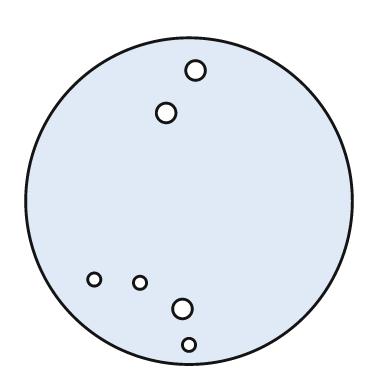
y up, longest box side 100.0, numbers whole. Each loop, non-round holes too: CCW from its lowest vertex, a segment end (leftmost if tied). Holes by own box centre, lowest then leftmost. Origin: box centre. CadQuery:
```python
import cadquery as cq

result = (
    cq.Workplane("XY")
    .moveTo(0.0, 0.0)
    .circle(50.0)
    .moveTo(0.0, -44.0)
    .circle(2.0)
    .moveTo(-2.0, -33.0)
    .circle(3.0)
    .moveTo(-15.0, -25.0)
    .circle(2.0)
    .moveTo(-29.0, -24.0)
    .circle(2.0)
    .moveTo(-7.0, 27.0)
    .circle(3.0)
    .moveTo(2.0, 40.0)
    .circle(3.0)
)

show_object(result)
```